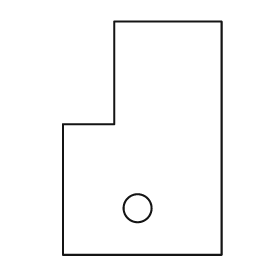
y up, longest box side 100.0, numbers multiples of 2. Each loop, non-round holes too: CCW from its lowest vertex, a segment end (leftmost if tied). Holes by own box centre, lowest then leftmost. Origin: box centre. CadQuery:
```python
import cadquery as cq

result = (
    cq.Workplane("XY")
    .moveTo(-34.0, -50.0)
    .lineTo(34.0, -50.0)
    .lineTo(34.0, 50.0)
    .lineTo(-12.0, 50.0)
    .lineTo(-12.0, 6.0)
    .lineTo(-34.0, 6.0)
    .close()
    .moveTo(-2.0, -30.0)
    .circle(6.0)
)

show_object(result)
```